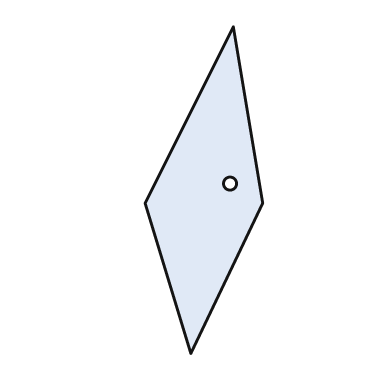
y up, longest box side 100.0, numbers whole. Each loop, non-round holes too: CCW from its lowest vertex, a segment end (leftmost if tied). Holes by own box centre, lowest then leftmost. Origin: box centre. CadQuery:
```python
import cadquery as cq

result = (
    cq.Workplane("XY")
    .moveTo(-4.0, -50.0)
    .lineTo(18.0, -4.0)
    .lineTo(9.0, 50.0)
    .lineTo(-18.0, -4.0)
    .close()
    .moveTo(8.0, 2.0)
    .circle(2.0)
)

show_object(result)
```